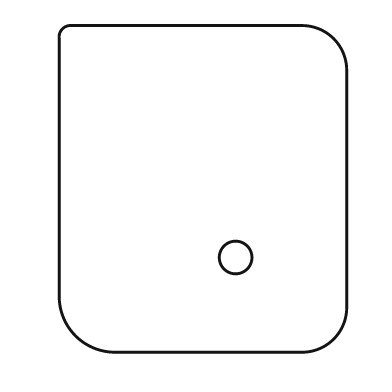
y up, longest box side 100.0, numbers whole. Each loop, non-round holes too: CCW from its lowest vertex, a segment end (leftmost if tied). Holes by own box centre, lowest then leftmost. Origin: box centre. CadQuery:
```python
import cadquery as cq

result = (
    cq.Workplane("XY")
    .moveTo(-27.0, -50.0)
    .lineTo(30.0, -50.0)
    .threePointArc((40.0, -46.0), (44.0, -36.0))
    .lineTo(44.0, 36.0)
    .threePointArc((40.0, 46.0), (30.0, 50.0))
    .lineTo(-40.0, 50.0)
    .threePointArc((-43.0, 49.0), (-44.0, 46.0))
    .lineTo(-44.0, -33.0)
    .threePointArc((-39.0, -45.0), (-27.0, -50.0))
    .close()
    .moveTo(10.0, -21.0)
    .circle(5.0)
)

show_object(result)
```